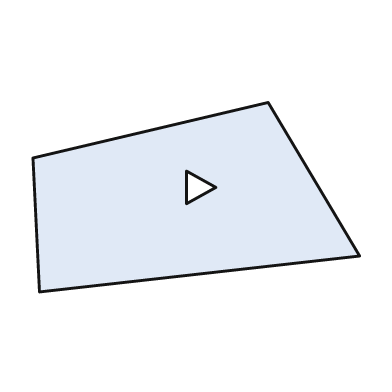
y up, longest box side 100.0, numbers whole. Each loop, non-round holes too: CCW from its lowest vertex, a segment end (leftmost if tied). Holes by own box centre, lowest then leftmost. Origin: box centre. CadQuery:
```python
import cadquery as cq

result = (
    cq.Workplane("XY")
    .moveTo(-48.0, -29.0)
    .lineTo(50.0, -18.0)
    .lineTo(22.0, 29.0)
    .lineTo(-50.0, 12.0)
    .close()
    .moveTo(-3.0, -2.0)
    .lineTo(6.0, 3.0)
    .lineTo(-3.0, 8.0)
    .close()
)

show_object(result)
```